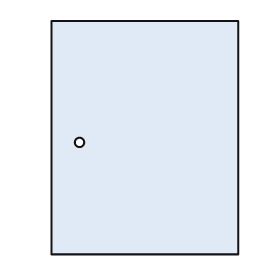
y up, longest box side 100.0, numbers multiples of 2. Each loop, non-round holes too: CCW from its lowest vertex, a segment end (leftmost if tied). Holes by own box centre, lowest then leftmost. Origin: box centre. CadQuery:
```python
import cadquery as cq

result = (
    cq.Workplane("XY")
    .moveTo(-40.0, -50.0)
    .lineTo(40.0, -50.0)
    .lineTo(40.0, 50.0)
    .lineTo(-40.0, 50.0)
    .close()
    .moveTo(-28.0, -2.0)
    .circle(2.0)
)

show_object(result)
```